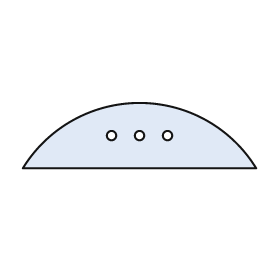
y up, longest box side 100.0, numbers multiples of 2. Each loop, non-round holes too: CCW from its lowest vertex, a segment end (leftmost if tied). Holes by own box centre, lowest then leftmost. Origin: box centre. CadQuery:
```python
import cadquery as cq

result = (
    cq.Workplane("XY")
    .moveTo(-50.0, -14.0)
    .lineTo(50.0, -14.0)
    .threePointArc((0.0, 14.0), (-50.0, -14.0))
    .close()
    .moveTo(-12.0, 0.0)
    .circle(2.0)
    .moveTo(0.0, 0.0)
    .circle(2.0)
    .moveTo(12.0, 0.0)
    .circle(2.0)
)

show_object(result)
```